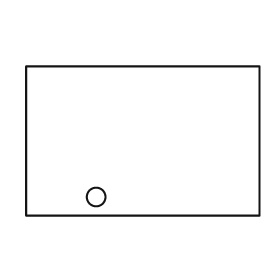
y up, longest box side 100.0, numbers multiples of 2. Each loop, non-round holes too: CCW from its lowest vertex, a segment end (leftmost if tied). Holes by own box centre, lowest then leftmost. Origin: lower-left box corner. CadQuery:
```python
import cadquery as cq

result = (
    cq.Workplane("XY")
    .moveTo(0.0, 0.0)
    .lineTo(100.0, 0.0)
    .lineTo(100.0, 64.0)
    .lineTo(0.0, 64.0)
    .close()
    .moveTo(30.0, 8.0)
    .circle(4.0)
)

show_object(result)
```